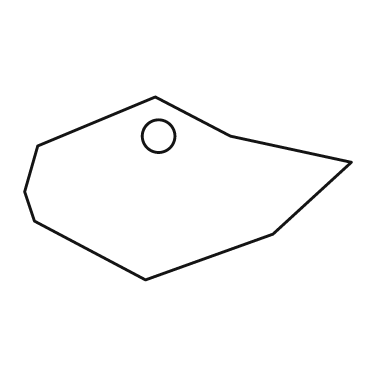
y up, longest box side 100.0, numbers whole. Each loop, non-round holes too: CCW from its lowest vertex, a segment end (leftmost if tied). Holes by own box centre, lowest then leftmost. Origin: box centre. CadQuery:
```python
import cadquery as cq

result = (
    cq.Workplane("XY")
    .moveTo(-13.0, -28.0)
    .lineTo(26.0, -14.0)
    .lineTo(50.0, 8.0)
    .lineTo(13.0, 16.0)
    .lineTo(-10.0, 28.0)
    .lineTo(-46.0, 13.0)
    .lineTo(-50.0, -1.0)
    .lineTo(-47.0, -10.0)
    .close()
    .moveTo(-9.0, 16.0)
    .circle(5.0)
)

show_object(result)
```